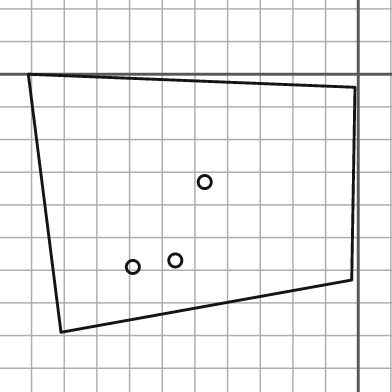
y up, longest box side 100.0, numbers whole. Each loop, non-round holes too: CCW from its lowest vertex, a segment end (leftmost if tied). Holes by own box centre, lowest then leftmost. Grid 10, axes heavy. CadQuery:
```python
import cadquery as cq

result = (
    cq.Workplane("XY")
    .moveTo(-91.0, -79.0)
    .lineTo(-2.0, -63.0)
    .lineTo(-1.0, -4.0)
    .lineTo(-101.0, 0.0)
    .close()
    .moveTo(-69.0, -59.0)
    .circle(2.0)
    .moveTo(-56.0, -57.0)
    .circle(2.0)
    .moveTo(-47.0, -33.0)
    .circle(2.0)
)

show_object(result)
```